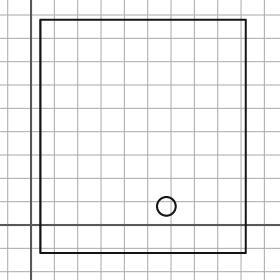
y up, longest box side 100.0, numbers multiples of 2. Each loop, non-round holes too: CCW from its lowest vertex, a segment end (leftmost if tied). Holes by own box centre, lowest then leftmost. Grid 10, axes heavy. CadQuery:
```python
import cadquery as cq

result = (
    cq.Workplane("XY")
    .moveTo(4.0, -12.0)
    .lineTo(92.0, -12.0)
    .lineTo(92.0, 88.0)
    .lineTo(4.0, 88.0)
    .close()
    .moveTo(58.0, 8.0)
    .circle(4.0)
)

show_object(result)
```